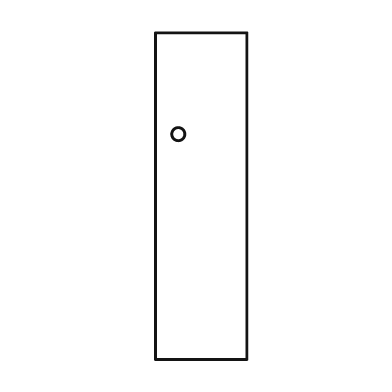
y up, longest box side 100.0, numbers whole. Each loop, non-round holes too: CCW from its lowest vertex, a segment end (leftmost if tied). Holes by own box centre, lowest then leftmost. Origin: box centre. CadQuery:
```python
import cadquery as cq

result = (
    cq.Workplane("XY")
    .moveTo(-14.0, -50.0)
    .lineTo(14.0, -50.0)
    .lineTo(14.0, 50.0)
    .lineTo(-14.0, 50.0)
    .close()
    .moveTo(-7.0, 19.0)
    .circle(2.0)
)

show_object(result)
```